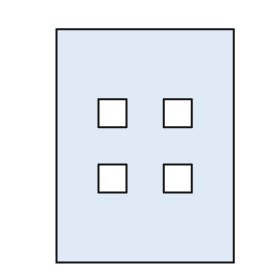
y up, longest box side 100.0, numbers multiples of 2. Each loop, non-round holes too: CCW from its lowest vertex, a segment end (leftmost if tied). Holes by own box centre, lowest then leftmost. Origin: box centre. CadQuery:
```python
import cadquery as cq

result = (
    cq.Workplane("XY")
    .moveTo(-38.0, -50.0)
    .lineTo(38.0, -50.0)
    .lineTo(38.0, 50.0)
    .lineTo(-38.0, 50.0)
    .close()
    .moveTo(-20.0, -20.0)
    .lineTo(-8.0, -20.0)
    .lineTo(-8.0, -8.0)
    .lineTo(-20.0, -8.0)
    .close()
    .moveTo(8.0, -20.0)
    .lineTo(20.0, -20.0)
    .lineTo(20.0, -8.0)
    .lineTo(8.0, -8.0)
    .close()
    .moveTo(-20.0, 8.0)
    .lineTo(-8.0, 8.0)
    .lineTo(-8.0, 20.0)
    .lineTo(-20.0, 20.0)
    .close()
    .moveTo(8.0, 8.0)
    .lineTo(20.0, 8.0)
    .lineTo(20.0, 20.0)
    .lineTo(8.0, 20.0)
    .close()
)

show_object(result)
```